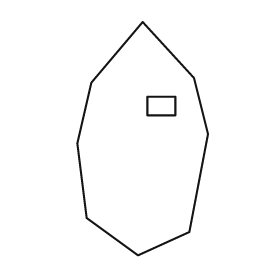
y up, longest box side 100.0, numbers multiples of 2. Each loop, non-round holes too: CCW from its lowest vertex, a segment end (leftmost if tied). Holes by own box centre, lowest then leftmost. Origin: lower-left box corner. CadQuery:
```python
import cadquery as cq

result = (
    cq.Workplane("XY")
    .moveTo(26.0, 0.0)
    .lineTo(48.0, 10.0)
    .lineTo(56.0, 52.0)
    .lineTo(50.0, 76.0)
    .lineTo(28.0, 100.0)
    .lineTo(6.0, 74.0)
    .lineTo(0.0, 48.0)
    .lineTo(4.0, 16.0)
    .close()
    .moveTo(30.0, 60.0)
    .lineTo(42.0, 60.0)
    .lineTo(42.0, 68.0)
    .lineTo(30.0, 68.0)
    .close()
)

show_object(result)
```